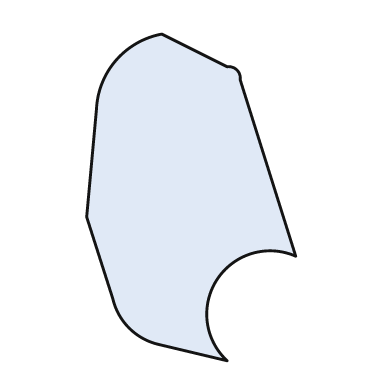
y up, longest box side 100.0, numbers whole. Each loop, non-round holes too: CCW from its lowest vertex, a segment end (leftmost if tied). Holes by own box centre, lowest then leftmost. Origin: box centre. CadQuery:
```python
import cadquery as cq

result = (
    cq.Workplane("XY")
    .moveTo(11.0, -50.0)
    .threePointArc((8.0, -25.0), (32.0, -18.0))
    .lineTo(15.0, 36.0)
    .threePointArc((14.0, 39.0), (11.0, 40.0))
    .lineTo(-9.0, 50.0)
    .threePointArc((-23.0, 42.0), (-29.0, 27.0))
    .lineTo(-32.0, -6.0)
    .lineTo(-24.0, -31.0)
    .threePointArc((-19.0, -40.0), (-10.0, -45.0))
    .close()
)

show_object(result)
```